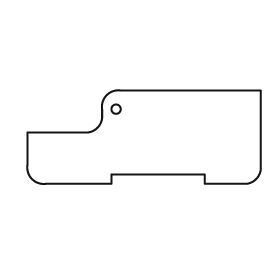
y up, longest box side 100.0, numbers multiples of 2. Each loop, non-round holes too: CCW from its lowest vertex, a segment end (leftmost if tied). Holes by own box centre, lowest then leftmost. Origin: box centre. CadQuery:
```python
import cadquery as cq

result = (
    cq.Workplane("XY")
    .moveTo(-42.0, -20.0)
    .lineTo(-14.0, -20.0)
    .lineTo(-14.0, -16.0)
    .lineTo(26.0, -16.0)
    .lineTo(26.0, -20.0)
    .lineTo(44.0, -20.0)
    .threePointArc((48.0, -18.0), (50.0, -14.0))
    .lineTo(50.0, 20.0)
    .lineTo(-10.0, 20.0)
    .threePointArc((-16.0, 18.0), (-18.0, 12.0))
    .lineTo(-18.0, 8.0)
    .threePointArc((-20.0, 4.0), (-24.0, 2.0))
    .lineTo(-50.0, 2.0)
    .lineTo(-50.0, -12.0)
    .threePointArc((-48.0, -18.0), (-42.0, -20.0))
    .close()
    .moveTo(-12.0, 12.0)
    .circle(2.0)
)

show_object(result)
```